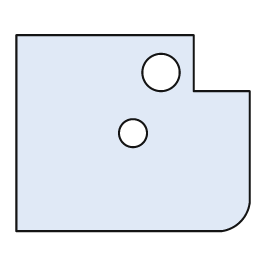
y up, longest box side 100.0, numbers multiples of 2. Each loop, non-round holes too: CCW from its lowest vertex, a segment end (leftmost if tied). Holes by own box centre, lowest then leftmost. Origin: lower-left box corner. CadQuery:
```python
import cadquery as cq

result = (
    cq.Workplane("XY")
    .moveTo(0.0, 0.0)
    .lineTo(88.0, 0.0)
    .threePointArc((96.0, 4.0), (100.0, 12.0))
    .lineTo(100.0, 60.0)
    .lineTo(76.0, 60.0)
    .lineTo(76.0, 84.0)
    .lineTo(0.0, 84.0)
    .close()
    .moveTo(50.0, 42.0)
    .circle(6.0)
    .moveTo(62.0, 68.0)
    .circle(8.0)
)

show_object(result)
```